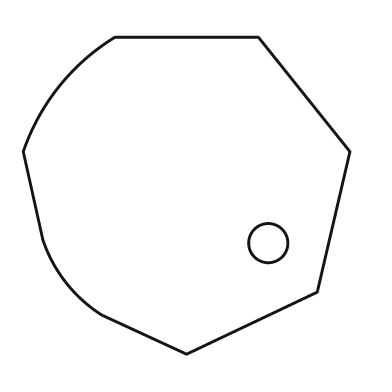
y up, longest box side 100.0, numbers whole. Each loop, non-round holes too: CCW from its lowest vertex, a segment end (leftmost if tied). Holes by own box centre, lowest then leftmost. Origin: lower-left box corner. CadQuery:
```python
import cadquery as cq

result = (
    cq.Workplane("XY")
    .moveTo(50.0, 0.0)
    .lineTo(90.0, 19.0)
    .lineTo(100.0, 62.0)
    .lineTo(72.0, 97.0)
    .lineTo(28.0, 97.0)
    .threePointArc((11.0, 82.0), (0.0, 62.0))
    .lineTo(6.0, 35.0)
    .threePointArc((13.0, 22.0), (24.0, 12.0))
    .close()
    .moveTo(75.0, 34.0)
    .circle(6.0)
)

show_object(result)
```